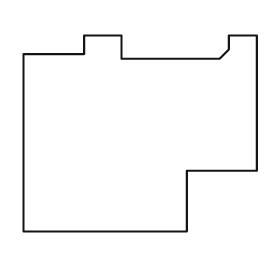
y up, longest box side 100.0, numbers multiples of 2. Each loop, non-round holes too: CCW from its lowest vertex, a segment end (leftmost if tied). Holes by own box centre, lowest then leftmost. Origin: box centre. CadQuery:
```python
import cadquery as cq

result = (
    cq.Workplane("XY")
    .moveTo(-50.0, -42.0)
    .lineTo(20.0, -42.0)
    .lineTo(20.0, -16.0)
    .lineTo(50.0, -16.0)
    .lineTo(50.0, 42.0)
    .lineTo(38.0, 42.0)
    .lineTo(38.0, 36.0)
    .lineTo(34.0, 32.0)
    .lineTo(-8.0, 32.0)
    .lineTo(-8.0, 42.0)
    .lineTo(-24.0, 42.0)
    .lineTo(-24.0, 34.0)
    .lineTo(-50.0, 34.0)
    .close()
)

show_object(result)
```